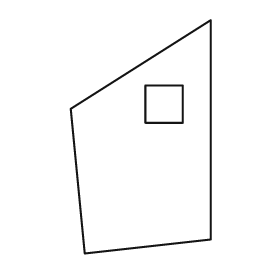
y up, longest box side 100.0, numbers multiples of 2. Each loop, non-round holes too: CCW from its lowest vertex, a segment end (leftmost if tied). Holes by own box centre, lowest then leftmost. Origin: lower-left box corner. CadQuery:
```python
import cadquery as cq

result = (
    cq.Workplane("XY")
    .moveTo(6.0, 0.0)
    .lineTo(60.0, 6.0)
    .lineTo(60.0, 100.0)
    .lineTo(0.0, 62.0)
    .close()
    .moveTo(32.0, 56.0)
    .lineTo(48.0, 56.0)
    .lineTo(48.0, 72.0)
    .lineTo(32.0, 72.0)
    .close()
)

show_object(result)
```